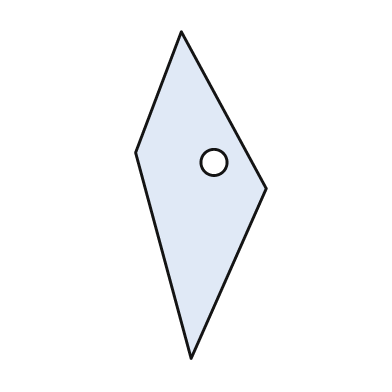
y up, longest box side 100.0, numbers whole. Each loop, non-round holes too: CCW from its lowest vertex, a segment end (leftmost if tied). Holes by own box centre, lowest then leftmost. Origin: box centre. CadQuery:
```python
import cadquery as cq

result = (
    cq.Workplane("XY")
    .moveTo(-3.0, -50.0)
    .lineTo(20.0, 2.0)
    .lineTo(-6.0, 50.0)
    .lineTo(-20.0, 13.0)
    .close()
    .moveTo(4.0, 10.0)
    .circle(4.0)
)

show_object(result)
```